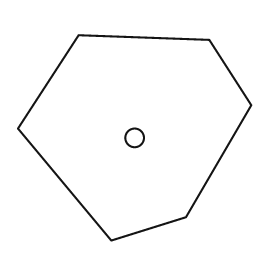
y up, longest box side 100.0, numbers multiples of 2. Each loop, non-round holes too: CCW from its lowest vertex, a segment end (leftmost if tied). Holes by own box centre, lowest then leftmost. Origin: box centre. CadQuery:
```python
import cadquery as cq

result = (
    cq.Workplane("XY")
    .moveTo(-10.0, -44.0)
    .lineTo(22.0, -34.0)
    .lineTo(50.0, 14.0)
    .lineTo(32.0, 42.0)
    .lineTo(-24.0, 44.0)
    .lineTo(-50.0, 4.0)
    .close()
    .moveTo(0.0, 0.0)
    .circle(4.0)
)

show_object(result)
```